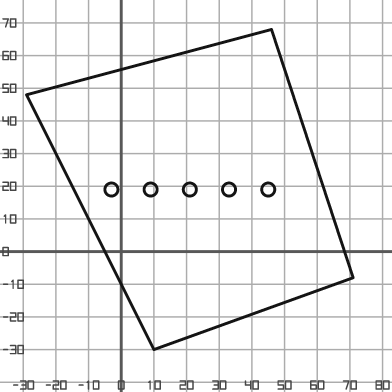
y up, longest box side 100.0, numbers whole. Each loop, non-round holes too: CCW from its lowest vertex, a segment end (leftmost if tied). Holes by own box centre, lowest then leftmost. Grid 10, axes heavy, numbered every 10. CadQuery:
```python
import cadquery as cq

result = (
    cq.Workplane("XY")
    .moveTo(10.0, -30.0)
    .lineTo(71.0, -8.0)
    .lineTo(46.0, 68.0)
    .lineTo(-29.0, 48.0)
    .close()
    .moveTo(-3.0, 19.0)
    .circle(2.0)
    .moveTo(9.0, 19.0)
    .circle(2.0)
    .moveTo(21.0, 19.0)
    .circle(2.0)
    .moveTo(33.0, 19.0)
    .circle(2.0)
    .moveTo(45.0, 19.0)
    .circle(2.0)
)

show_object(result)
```